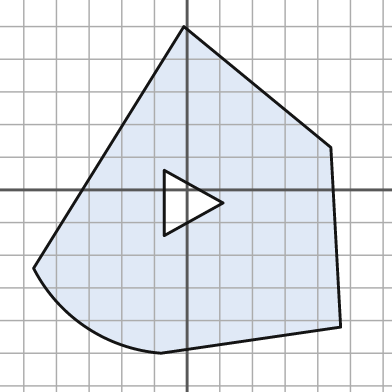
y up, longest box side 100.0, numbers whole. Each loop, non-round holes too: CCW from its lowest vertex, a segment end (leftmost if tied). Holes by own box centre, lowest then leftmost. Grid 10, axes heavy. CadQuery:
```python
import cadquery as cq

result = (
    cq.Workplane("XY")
    .moveTo(-8.0, -50.0)
    .lineTo(47.0, -42.0)
    .lineTo(44.0, 13.0)
    .lineTo(-1.0, 50.0)
    .lineTo(-47.0, -24.0)
    .threePointArc((-31.0, -42.0), (-8.0, -50.0))
    .close()
    .moveTo(-7.0, -14.0)
    .lineTo(11.0, -4.0)
    .lineTo(-7.0, 6.0)
    .close()
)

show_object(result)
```